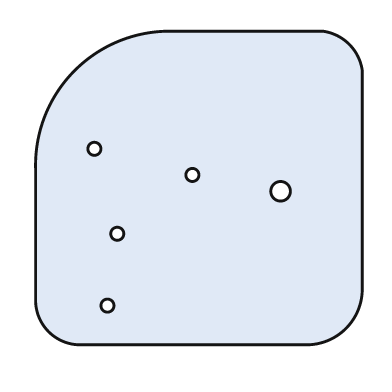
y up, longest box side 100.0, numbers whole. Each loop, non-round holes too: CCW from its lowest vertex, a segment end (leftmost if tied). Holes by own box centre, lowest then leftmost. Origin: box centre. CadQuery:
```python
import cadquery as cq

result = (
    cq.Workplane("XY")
    .moveTo(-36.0, -48.0)
    .lineTo(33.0, -48.0)
    .threePointArc((45.0, -43.0), (50.0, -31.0))
    .lineTo(50.0, 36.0)
    .threePointArc((46.0, 44.0), (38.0, 48.0))
    .lineTo(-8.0, 48.0)
    .threePointArc((-38.0, 36.0), (-50.0, 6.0))
    .lineTo(-50.0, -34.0)
    .threePointArc((-46.0, -44.0), (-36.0, -48.0))
    .close()
    .moveTo(-28.0, -36.0)
    .circle(2.0)
    .moveTo(-25.0, -14.0)
    .circle(2.0)
    .moveTo(25.0, -1.0)
    .circle(3.0)
    .moveTo(-2.0, 4.0)
    .circle(2.0)
    .moveTo(-32.0, 12.0)
    .circle(2.0)
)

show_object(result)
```